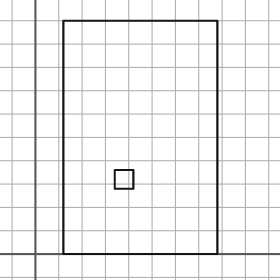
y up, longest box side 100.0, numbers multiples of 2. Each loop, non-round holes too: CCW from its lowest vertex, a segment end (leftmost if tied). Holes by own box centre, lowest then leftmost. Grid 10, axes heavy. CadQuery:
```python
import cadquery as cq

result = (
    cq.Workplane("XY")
    .moveTo(12.0, 0.0)
    .lineTo(78.0, 0.0)
    .lineTo(78.0, 100.0)
    .lineTo(12.0, 100.0)
    .close()
    .moveTo(34.0, 28.0)
    .lineTo(42.0, 28.0)
    .lineTo(42.0, 36.0)
    .lineTo(34.0, 36.0)
    .close()
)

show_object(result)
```